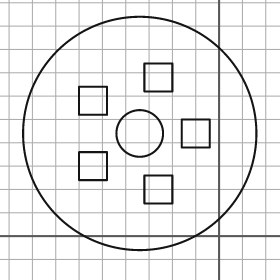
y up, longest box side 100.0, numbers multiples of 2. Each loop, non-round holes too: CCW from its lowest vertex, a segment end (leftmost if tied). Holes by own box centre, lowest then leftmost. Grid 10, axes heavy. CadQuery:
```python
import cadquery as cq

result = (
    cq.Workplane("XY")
    .moveTo(-34.0, 44.0)
    .circle(50.0)
    .moveTo(-32.0, 14.0)
    .lineTo(-20.0, 14.0)
    .lineTo(-20.0, 26.0)
    .lineTo(-32.0, 26.0)
    .close()
    .moveTo(-60.0, 24.0)
    .lineTo(-48.0, 24.0)
    .lineTo(-48.0, 36.0)
    .lineTo(-60.0, 36.0)
    .close()
    .moveTo(-34.0, 44.0)
    .circle(10.0)
    .moveTo(-16.0, 38.0)
    .lineTo(-4.0, 38.0)
    .lineTo(-4.0, 50.0)
    .lineTo(-16.0, 50.0)
    .close()
    .moveTo(-60.0, 52.0)
    .lineTo(-48.0, 52.0)
    .lineTo(-48.0, 64.0)
    .lineTo(-60.0, 64.0)
    .close()
    .moveTo(-32.0, 62.0)
    .lineTo(-20.0, 62.0)
    .lineTo(-20.0, 74.0)
    .lineTo(-32.0, 74.0)
    .close()
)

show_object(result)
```